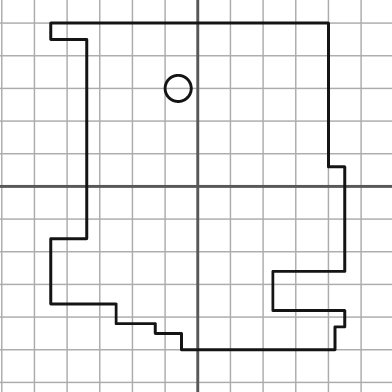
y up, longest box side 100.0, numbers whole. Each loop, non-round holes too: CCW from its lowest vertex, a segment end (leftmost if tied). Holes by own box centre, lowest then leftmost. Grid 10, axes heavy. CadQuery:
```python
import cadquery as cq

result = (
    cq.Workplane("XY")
    .moveTo(-5.0, -50.0)
    .lineTo(42.0, -50.0)
    .lineTo(42.0, -43.0)
    .lineTo(45.0, -43.0)
    .lineTo(45.0, -38.0)
    .lineTo(23.0, -38.0)
    .lineTo(23.0, -26.0)
    .lineTo(45.0, -26.0)
    .lineTo(45.0, 6.0)
    .lineTo(40.0, 6.0)
    .lineTo(40.0, 50.0)
    .lineTo(-45.0, 50.0)
    .lineTo(-45.0, 45.0)
    .lineTo(-34.0, 45.0)
    .lineTo(-34.0, -16.0)
    .lineTo(-45.0, -16.0)
    .lineTo(-45.0, -36.0)
    .lineTo(-25.0, -36.0)
    .lineTo(-25.0, -42.0)
    .lineTo(-13.0, -42.0)
    .lineTo(-13.0, -45.0)
    .lineTo(-5.0, -45.0)
    .close()
    .moveTo(-6.0, 30.0)
    .circle(4.0)
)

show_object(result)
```